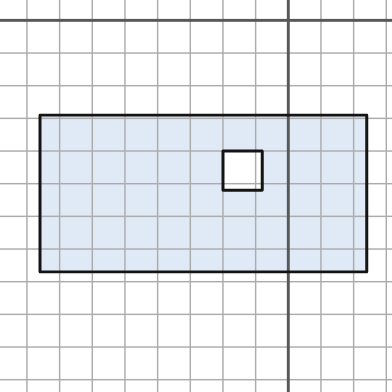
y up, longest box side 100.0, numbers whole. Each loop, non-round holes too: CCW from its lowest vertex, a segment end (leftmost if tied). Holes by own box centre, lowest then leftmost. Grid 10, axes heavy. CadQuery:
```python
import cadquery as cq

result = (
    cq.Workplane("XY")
    .moveTo(-76.0, -77.0)
    .lineTo(24.0, -77.0)
    .lineTo(24.0, -29.0)
    .lineTo(-76.0, -29.0)
    .close()
    .moveTo(-20.0, -52.0)
    .lineTo(-8.0, -52.0)
    .lineTo(-8.0, -40.0)
    .lineTo(-20.0, -40.0)
    .close()
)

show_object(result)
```